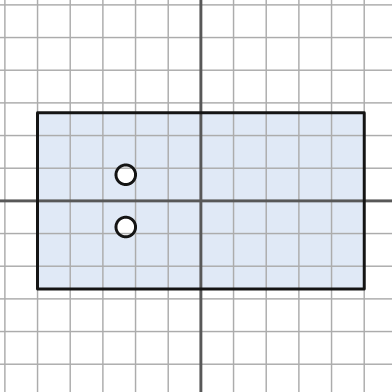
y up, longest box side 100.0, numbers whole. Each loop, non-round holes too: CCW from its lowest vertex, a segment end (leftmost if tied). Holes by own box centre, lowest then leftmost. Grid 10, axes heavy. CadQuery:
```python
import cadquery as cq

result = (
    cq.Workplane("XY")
    .moveTo(-50.0, -27.0)
    .lineTo(50.0, -27.0)
    .lineTo(50.0, 27.0)
    .lineTo(-50.0, 27.0)
    .close()
    .moveTo(-23.0, -8.0)
    .circle(3.0)
    .moveTo(-23.0, 8.0)
    .circle(3.0)
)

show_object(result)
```